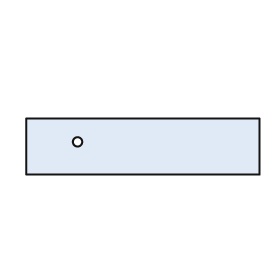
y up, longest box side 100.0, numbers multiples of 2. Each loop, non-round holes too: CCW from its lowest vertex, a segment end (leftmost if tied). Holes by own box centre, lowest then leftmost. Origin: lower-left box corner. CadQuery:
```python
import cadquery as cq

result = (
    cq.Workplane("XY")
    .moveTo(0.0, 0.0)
    .lineTo(100.0, 0.0)
    .lineTo(100.0, 24.0)
    .lineTo(0.0, 24.0)
    .close()
    .moveTo(22.0, 14.0)
    .circle(2.0)
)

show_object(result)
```